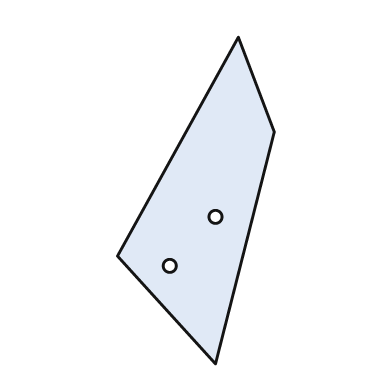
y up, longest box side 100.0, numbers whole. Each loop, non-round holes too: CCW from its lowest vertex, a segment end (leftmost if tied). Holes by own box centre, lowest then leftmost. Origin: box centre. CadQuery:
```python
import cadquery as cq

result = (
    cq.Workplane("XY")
    .moveTo(6.0, -50.0)
    .lineTo(24.0, 21.0)
    .lineTo(13.0, 50.0)
    .lineTo(-24.0, -17.0)
    .close()
    .moveTo(-8.0, -20.0)
    .circle(2.0)
    .moveTo(6.0, -5.0)
    .circle(2.0)
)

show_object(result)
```